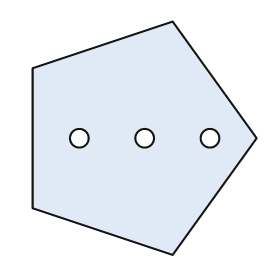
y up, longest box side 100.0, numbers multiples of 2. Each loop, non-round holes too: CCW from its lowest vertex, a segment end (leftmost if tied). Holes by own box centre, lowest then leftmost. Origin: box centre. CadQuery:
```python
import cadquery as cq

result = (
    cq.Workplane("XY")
    .moveTo(12.0, -50.0)
    .lineTo(48.0, 0.0)
    .lineTo(12.0, 50.0)
    .lineTo(-48.0, 30.0)
    .lineTo(-48.0, -30.0)
    .close()
    .moveTo(-28.0, 0.0)
    .circle(4.0)
    .moveTo(0.0, 0.0)
    .circle(4.0)
    .moveTo(28.0, 0.0)
    .circle(4.0)
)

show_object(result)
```